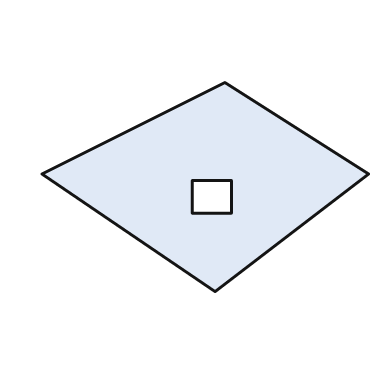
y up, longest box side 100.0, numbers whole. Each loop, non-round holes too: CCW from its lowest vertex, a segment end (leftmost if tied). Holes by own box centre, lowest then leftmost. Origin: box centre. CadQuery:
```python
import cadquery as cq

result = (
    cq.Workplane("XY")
    .moveTo(3.0, -32.0)
    .lineTo(50.0, 4.0)
    .lineTo(6.0, 32.0)
    .lineTo(-50.0, 4.0)
    .close()
    .moveTo(-4.0, -8.0)
    .lineTo(8.0, -8.0)
    .lineTo(8.0, 2.0)
    .lineTo(-4.0, 2.0)
    .close()
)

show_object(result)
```